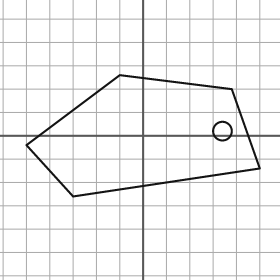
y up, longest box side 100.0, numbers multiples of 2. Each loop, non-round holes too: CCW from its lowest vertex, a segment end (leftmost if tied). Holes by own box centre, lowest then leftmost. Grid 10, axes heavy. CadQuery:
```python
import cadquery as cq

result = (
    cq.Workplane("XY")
    .moveTo(-30.0, -26.0)
    .lineTo(50.0, -14.0)
    .lineTo(38.0, 20.0)
    .lineTo(-10.0, 26.0)
    .lineTo(-50.0, -4.0)
    .close()
    .moveTo(34.0, 2.0)
    .circle(4.0)
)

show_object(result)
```